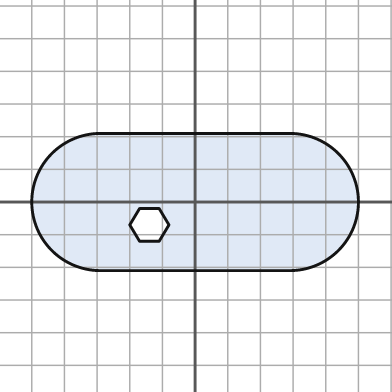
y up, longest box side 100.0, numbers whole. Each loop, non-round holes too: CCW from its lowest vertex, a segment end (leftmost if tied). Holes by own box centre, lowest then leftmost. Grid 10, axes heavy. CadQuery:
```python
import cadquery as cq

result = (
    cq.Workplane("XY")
    .moveTo(-29.0, -21.0)
    .lineTo(29.0, -21.0)
    .threePointArc((50.0, 0.0), (29.0, 21.0))
    .lineTo(-29.0, 21.0)
    .threePointArc((-50.0, 0.0), (-29.0, -21.0))
    .close()
    .moveTo(-17.0, -12.0)
    .lineTo(-11.0, -12.0)
    .lineTo(-8.0, -7.0)
    .lineTo(-11.0, -2.0)
    .lineTo(-17.0, -2.0)
    .lineTo(-20.0, -7.0)
    .close()
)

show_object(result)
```